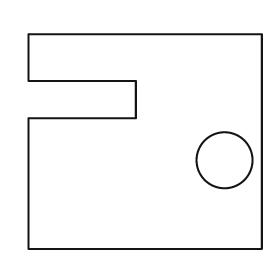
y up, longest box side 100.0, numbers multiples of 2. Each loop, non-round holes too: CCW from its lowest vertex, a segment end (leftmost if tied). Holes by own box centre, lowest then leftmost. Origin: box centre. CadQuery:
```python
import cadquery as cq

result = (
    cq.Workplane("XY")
    .moveTo(-50.0, -46.0)
    .lineTo(50.0, -46.0)
    .lineTo(50.0, 46.0)
    .lineTo(-50.0, 46.0)
    .lineTo(-50.0, 26.0)
    .lineTo(-4.0, 26.0)
    .lineTo(-4.0, 10.0)
    .lineTo(-50.0, 10.0)
    .close()
    .moveTo(34.0, -8.0)
    .circle(12.0)
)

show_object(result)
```